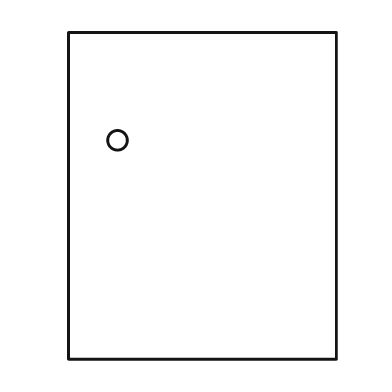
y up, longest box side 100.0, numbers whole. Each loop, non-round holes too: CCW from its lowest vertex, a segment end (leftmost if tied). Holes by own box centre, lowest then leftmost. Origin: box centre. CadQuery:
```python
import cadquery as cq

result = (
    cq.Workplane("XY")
    .moveTo(-41.0, -50.0)
    .lineTo(41.0, -50.0)
    .lineTo(41.0, 50.0)
    .lineTo(-41.0, 50.0)
    .close()
    .moveTo(-26.0, 17.0)
    .circle(3.0)
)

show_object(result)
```